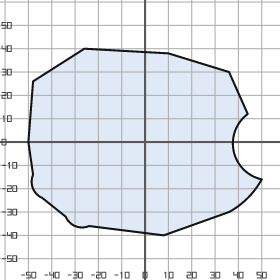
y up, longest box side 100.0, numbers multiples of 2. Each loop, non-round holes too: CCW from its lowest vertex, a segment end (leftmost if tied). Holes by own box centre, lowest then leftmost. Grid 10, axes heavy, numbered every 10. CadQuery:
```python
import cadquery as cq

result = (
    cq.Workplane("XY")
    .moveTo(8.0, -40.0)
    .lineTo(36.0, -30.0)
    .threePointArc((44.0, -24.0), (50.0, -16.0))
    .threePointArc((38.0, -4.0), (44.0, 12.0))
    .lineTo(36.0, 30.0)
    .lineTo(10.0, 38.0)
    .lineTo(-26.0, 40.0)
    .lineTo(-48.0, 26.0)
    .lineTo(-50.0, 0.0)
    .lineTo(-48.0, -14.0)
    .threePointArc((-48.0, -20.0), (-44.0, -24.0))
    .lineTo(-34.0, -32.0)
    .threePointArc((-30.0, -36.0), (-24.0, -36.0))
    .close()
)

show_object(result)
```